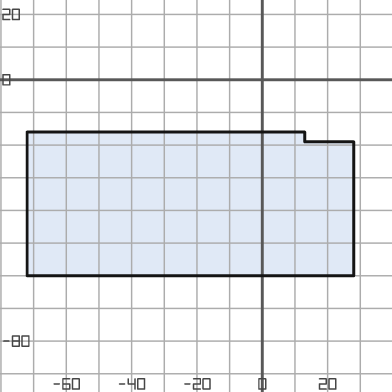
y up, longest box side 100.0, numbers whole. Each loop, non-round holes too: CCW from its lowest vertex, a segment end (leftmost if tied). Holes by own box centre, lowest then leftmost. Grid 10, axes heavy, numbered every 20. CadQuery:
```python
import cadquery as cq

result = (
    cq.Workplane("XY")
    .moveTo(-72.0, -60.0)
    .lineTo(28.0, -60.0)
    .lineTo(28.0, -19.0)
    .lineTo(13.0, -19.0)
    .lineTo(13.0, -16.0)
    .lineTo(-72.0, -16.0)
    .close()
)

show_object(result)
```